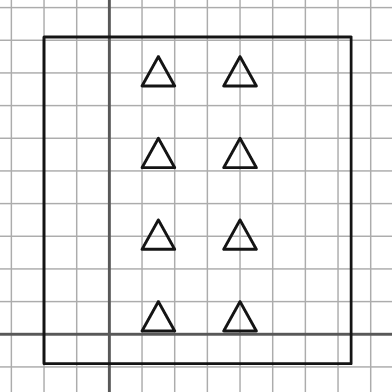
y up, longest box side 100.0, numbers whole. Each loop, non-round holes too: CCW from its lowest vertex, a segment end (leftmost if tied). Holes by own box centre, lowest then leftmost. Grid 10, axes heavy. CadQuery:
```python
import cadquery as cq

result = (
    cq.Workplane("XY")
    .moveTo(-20.0, -9.0)
    .lineTo(74.0, -9.0)
    .lineTo(74.0, 91.0)
    .lineTo(-20.0, 91.0)
    .close()
    .moveTo(10.0, 1.0)
    .lineTo(20.0, 1.0)
    .lineTo(15.0, 10.0)
    .close()
    .moveTo(35.0, 1.0)
    .lineTo(45.0, 1.0)
    .lineTo(40.0, 10.0)
    .close()
    .moveTo(10.0, 26.0)
    .lineTo(20.0, 26.0)
    .lineTo(15.0, 35.0)
    .close()
    .moveTo(35.0, 26.0)
    .lineTo(45.0, 26.0)
    .lineTo(40.0, 35.0)
    .close()
    .moveTo(10.0, 51.0)
    .lineTo(20.0, 51.0)
    .lineTo(15.0, 60.0)
    .close()
    .moveTo(35.0, 51.0)
    .lineTo(45.0, 51.0)
    .lineTo(40.0, 60.0)
    .close()
    .moveTo(10.0, 76.0)
    .lineTo(20.0, 76.0)
    .lineTo(15.0, 85.0)
    .close()
    .moveTo(35.0, 76.0)
    .lineTo(45.0, 76.0)
    .lineTo(40.0, 85.0)
    .close()
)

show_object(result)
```